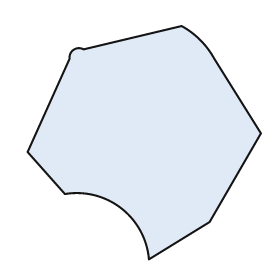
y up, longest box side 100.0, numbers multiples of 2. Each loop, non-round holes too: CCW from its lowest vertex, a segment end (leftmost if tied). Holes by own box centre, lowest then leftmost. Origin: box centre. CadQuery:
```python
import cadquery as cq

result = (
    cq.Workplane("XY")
    .moveTo(2.0, -50.0)
    .lineTo(28.0, -34.0)
    .lineTo(50.0, 4.0)
    .lineTo(30.0, 36.0)
    .threePointArc((24.0, 44.0), (16.0, 50.0))
    .lineTo(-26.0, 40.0)
    .threePointArc((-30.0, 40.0), (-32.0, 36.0))
    .lineTo(-50.0, -4.0)
    .lineTo(-34.0, -22.0)
    .threePointArc((-10.0, -28.0), (2.0, -50.0))
    .close()
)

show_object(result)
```